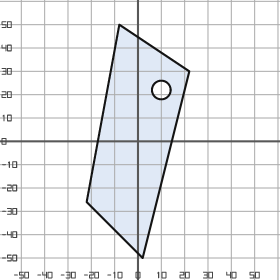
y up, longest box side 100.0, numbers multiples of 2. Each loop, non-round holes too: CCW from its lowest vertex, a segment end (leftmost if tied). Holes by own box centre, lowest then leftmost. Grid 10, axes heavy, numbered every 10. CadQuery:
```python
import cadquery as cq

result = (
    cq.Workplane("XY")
    .moveTo(2.0, -50.0)
    .lineTo(22.0, 30.0)
    .lineTo(-8.0, 50.0)
    .lineTo(-22.0, -26.0)
    .close()
    .moveTo(10.0, 22.0)
    .circle(4.0)
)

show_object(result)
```